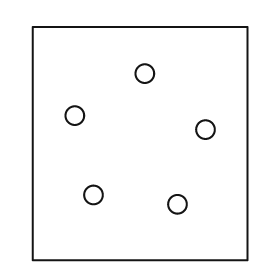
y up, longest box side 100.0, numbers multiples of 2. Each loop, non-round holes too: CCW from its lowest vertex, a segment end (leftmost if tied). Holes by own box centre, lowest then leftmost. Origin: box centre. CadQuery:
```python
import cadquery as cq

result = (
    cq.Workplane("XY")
    .moveTo(-46.0, -50.0)
    .lineTo(46.0, -50.0)
    .lineTo(46.0, 50.0)
    .lineTo(-46.0, 50.0)
    .close()
    .moveTo(16.0, -26.0)
    .circle(4.0)
    .moveTo(-20.0, -22.0)
    .circle(4.0)
    .moveTo(28.0, 6.0)
    .circle(4.0)
    .moveTo(-28.0, 12.0)
    .circle(4.0)
    .moveTo(2.0, 30.0)
    .circle(4.0)
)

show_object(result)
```